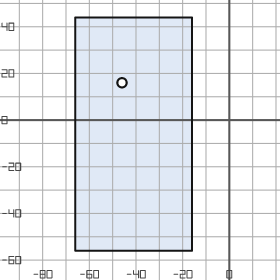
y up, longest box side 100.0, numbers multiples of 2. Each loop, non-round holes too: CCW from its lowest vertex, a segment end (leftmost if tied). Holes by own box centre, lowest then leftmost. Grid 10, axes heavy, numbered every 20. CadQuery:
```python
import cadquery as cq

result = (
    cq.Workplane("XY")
    .moveTo(-66.0, -56.0)
    .lineTo(-16.0, -56.0)
    .lineTo(-16.0, 44.0)
    .lineTo(-66.0, 44.0)
    .close()
    .moveTo(-46.0, 16.0)
    .circle(2.0)
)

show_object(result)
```